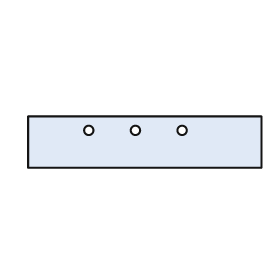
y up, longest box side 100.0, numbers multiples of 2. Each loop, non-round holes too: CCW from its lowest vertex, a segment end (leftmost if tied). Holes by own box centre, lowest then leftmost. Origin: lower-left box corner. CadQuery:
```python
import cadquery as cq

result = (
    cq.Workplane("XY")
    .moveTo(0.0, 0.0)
    .lineTo(100.0, 0.0)
    .lineTo(100.0, 22.0)
    .lineTo(0.0, 22.0)
    .close()
    .moveTo(26.0, 16.0)
    .circle(2.0)
    .moveTo(46.0, 16.0)
    .circle(2.0)
    .moveTo(66.0, 16.0)
    .circle(2.0)
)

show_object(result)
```